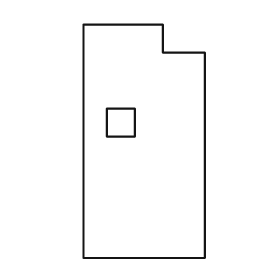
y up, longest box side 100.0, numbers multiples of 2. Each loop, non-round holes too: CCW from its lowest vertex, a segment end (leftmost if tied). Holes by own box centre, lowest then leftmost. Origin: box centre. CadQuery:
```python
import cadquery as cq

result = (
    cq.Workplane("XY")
    .moveTo(-26.0, -50.0)
    .lineTo(26.0, -50.0)
    .lineTo(26.0, 38.0)
    .lineTo(8.0, 38.0)
    .lineTo(8.0, 50.0)
    .lineTo(-26.0, 50.0)
    .close()
    .moveTo(-16.0, 2.0)
    .lineTo(-4.0, 2.0)
    .lineTo(-4.0, 14.0)
    .lineTo(-16.0, 14.0)
    .close()
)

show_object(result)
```